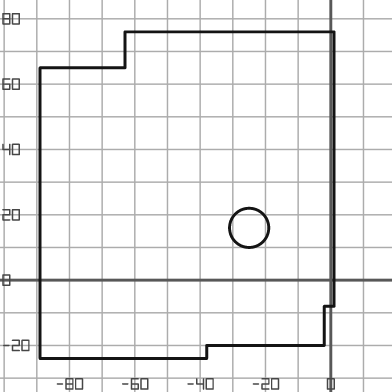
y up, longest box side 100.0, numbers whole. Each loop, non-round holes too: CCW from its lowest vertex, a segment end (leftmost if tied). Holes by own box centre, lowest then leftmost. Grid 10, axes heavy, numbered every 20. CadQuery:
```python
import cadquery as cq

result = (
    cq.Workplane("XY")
    .moveTo(-89.0, -24.0)
    .lineTo(-38.0, -24.0)
    .lineTo(-38.0, -20.0)
    .lineTo(-2.0, -20.0)
    .lineTo(-2.0, -8.0)
    .lineTo(1.0, -8.0)
    .lineTo(1.0, 76.0)
    .lineTo(-63.0, 76.0)
    .lineTo(-63.0, 65.0)
    .lineTo(-89.0, 65.0)
    .close()
    .moveTo(-25.0, 16.0)
    .circle(6.0)
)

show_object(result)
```